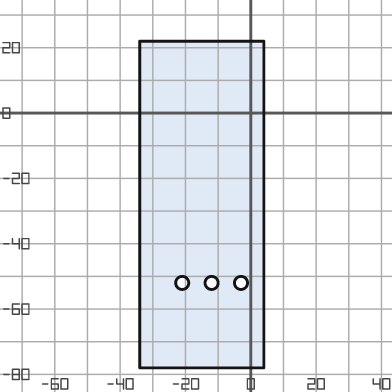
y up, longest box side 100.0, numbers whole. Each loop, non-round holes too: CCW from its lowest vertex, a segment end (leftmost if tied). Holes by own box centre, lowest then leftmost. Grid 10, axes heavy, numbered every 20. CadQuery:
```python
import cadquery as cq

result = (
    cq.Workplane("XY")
    .moveTo(-34.0, -78.0)
    .lineTo(4.0, -78.0)
    .lineTo(4.0, 22.0)
    .lineTo(-34.0, 22.0)
    .close()
    .moveTo(-21.0, -52.0)
    .circle(2.0)
    .moveTo(-12.0, -52.0)
    .circle(2.0)
    .moveTo(-3.0, -52.0)
    .circle(2.0)
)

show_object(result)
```